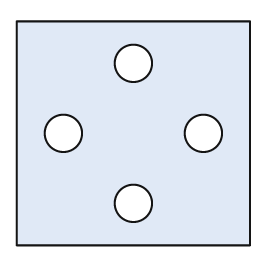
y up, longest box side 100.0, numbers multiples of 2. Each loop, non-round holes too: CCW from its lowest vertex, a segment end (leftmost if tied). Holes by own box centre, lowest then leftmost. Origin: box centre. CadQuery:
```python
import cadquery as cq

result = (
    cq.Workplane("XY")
    .moveTo(-50.0, -48.0)
    .lineTo(50.0, -48.0)
    .lineTo(50.0, 48.0)
    .lineTo(-50.0, 48.0)
    .close()
    .moveTo(0.0, -30.0)
    .circle(8.0)
    .moveTo(-30.0, 0.0)
    .circle(8.0)
    .moveTo(30.0, 0.0)
    .circle(8.0)
    .moveTo(0.0, 30.0)
    .circle(8.0)
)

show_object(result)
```